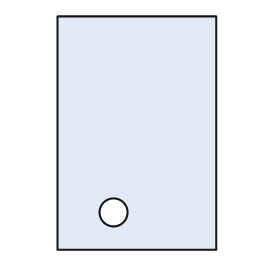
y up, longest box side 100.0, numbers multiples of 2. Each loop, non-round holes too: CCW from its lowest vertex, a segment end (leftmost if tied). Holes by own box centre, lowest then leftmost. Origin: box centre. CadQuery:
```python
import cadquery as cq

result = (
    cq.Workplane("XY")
    .moveTo(-34.0, -50.0)
    .lineTo(34.0, -50.0)
    .lineTo(34.0, 50.0)
    .lineTo(-34.0, 50.0)
    .close()
    .moveTo(-10.0, -34.0)
    .circle(6.0)
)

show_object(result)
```